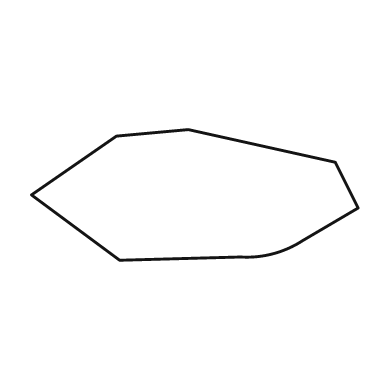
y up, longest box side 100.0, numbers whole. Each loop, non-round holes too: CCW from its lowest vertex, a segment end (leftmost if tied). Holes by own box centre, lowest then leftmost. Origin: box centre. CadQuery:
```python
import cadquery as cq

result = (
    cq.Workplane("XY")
    .moveTo(-23.0, -20.0)
    .lineTo(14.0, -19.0)
    .threePointArc((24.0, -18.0), (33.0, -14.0))
    .lineTo(50.0, -4.0)
    .lineTo(43.0, 10.0)
    .lineTo(-2.0, 20.0)
    .lineTo(-24.0, 18.0)
    .lineTo(-50.0, 0.0)
    .close()
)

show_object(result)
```